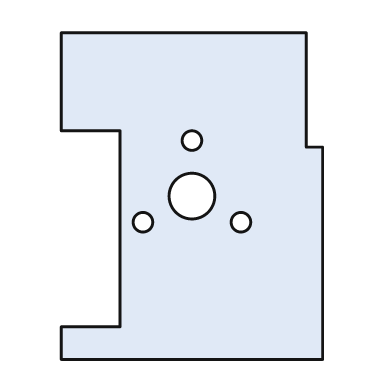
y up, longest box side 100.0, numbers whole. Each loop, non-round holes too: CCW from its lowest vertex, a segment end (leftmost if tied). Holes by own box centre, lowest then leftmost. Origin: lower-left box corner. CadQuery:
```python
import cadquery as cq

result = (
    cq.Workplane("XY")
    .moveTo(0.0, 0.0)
    .lineTo(80.0, 0.0)
    .lineTo(80.0, 65.0)
    .lineTo(75.0, 65.0)
    .lineTo(75.0, 100.0)
    .lineTo(0.0, 100.0)
    .lineTo(0.0, 70.0)
    .lineTo(18.0, 70.0)
    .lineTo(18.0, 10.0)
    .lineTo(0.0, 10.0)
    .close()
    .moveTo(25.0, 42.0)
    .circle(3.0)
    .moveTo(55.0, 42.0)
    .circle(3.0)
    .moveTo(40.0, 50.0)
    .circle(7.0)
    .moveTo(40.0, 67.0)
    .circle(3.0)
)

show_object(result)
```